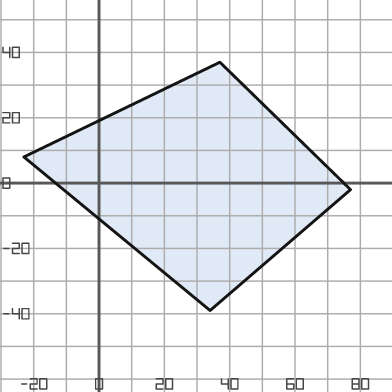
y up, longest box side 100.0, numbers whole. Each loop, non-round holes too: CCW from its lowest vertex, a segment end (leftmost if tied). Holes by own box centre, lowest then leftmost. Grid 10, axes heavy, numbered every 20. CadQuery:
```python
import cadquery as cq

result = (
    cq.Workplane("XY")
    .moveTo(34.0, -39.0)
    .lineTo(77.0, -2.0)
    .lineTo(37.0, 37.0)
    .lineTo(-23.0, 8.0)
    .close()
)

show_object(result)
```